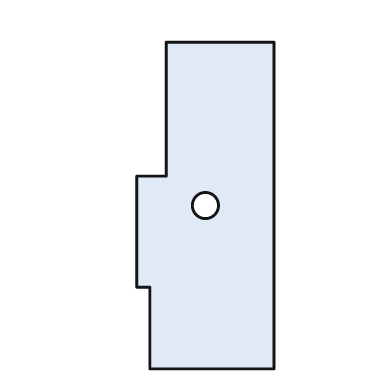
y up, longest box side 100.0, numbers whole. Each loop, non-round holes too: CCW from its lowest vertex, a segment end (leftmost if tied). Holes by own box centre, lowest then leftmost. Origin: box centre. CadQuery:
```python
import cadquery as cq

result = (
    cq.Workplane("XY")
    .moveTo(-17.0, -50.0)
    .lineTo(21.0, -50.0)
    .lineTo(21.0, 50.0)
    .lineTo(-12.0, 50.0)
    .lineTo(-12.0, 9.0)
    .lineTo(-21.0, 9.0)
    .lineTo(-21.0, -25.0)
    .lineTo(-17.0, -25.0)
    .close()
    .moveTo(0.0, 0.0)
    .circle(4.0)
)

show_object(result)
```